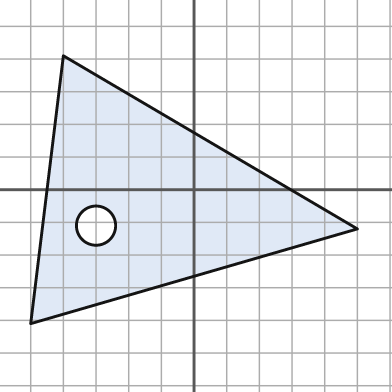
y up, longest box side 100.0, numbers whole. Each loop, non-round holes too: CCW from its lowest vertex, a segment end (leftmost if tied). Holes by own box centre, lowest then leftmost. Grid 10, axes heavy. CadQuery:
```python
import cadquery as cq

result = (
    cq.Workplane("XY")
    .moveTo(-50.0, -41.0)
    .lineTo(50.0, -12.0)
    .lineTo(-40.0, 41.0)
    .close()
    .moveTo(-30.0, -11.0)
    .circle(6.0)
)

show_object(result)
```